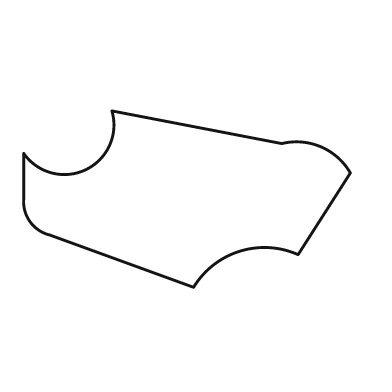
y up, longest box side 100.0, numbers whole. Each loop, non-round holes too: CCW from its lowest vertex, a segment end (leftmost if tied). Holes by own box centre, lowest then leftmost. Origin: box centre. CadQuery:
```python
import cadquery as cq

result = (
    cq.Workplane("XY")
    .moveTo(2.0, -27.0)
    .threePointArc((16.0, -16.0), (34.0, -17.0))
    .lineTo(50.0, 8.0)
    .threePointArc((41.0, 16.0), (29.0, 17.0))
    .lineTo(-23.0, 27.0)
    .threePointArc((-31.0, 9.0), (-50.0, 14.0))
    .lineTo(-50.0, 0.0)
    .threePointArc((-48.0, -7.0), (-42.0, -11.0))
    .close()
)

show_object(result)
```